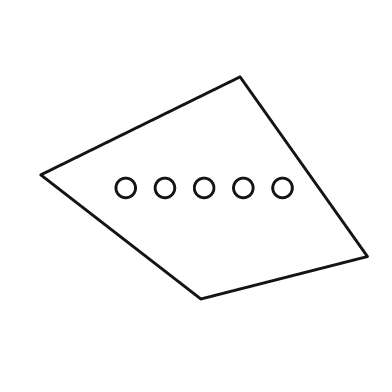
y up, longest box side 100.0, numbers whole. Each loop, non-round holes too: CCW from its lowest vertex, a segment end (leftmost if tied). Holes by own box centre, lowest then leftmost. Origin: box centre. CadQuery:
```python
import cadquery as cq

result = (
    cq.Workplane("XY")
    .moveTo(-1.0, -34.0)
    .lineTo(50.0, -21.0)
    .lineTo(11.0, 34.0)
    .lineTo(-50.0, 4.0)
    .close()
    .moveTo(-24.0, 0.0)
    .circle(3.0)
    .moveTo(-12.0, 0.0)
    .circle(3.0)
    .moveTo(0.0, 0.0)
    .circle(3.0)
    .moveTo(12.0, 0.0)
    .circle(3.0)
    .moveTo(24.0, 0.0)
    .circle(3.0)
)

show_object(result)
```